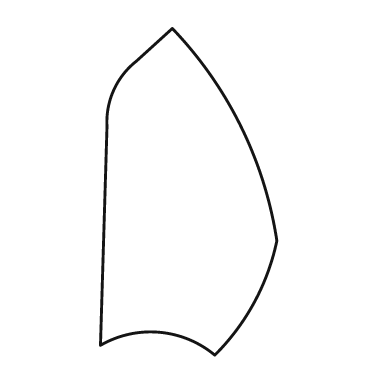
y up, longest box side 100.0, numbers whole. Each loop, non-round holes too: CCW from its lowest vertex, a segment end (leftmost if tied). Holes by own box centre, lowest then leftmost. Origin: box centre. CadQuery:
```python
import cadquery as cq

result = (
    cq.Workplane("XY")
    .moveTo(8.0, -50.0)
    .threePointArc((20.0, -34.0), (27.0, -15.0))
    .threePointArc((16.0, 20.0), (-5.0, 50.0))
    .lineTo(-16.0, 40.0)
    .threePointArc((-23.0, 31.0), (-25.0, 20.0))
    .lineTo(-27.0, -47.0)
    .threePointArc((-9.0, -43.0), (8.0, -50.0))
    .close()
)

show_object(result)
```